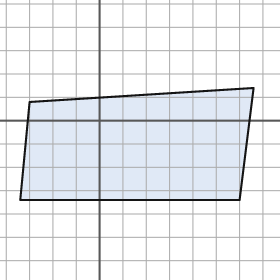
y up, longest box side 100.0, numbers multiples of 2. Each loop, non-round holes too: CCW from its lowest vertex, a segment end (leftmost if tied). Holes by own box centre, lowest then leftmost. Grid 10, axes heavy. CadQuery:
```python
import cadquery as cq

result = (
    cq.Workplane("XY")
    .moveTo(-34.0, -34.0)
    .lineTo(60.0, -34.0)
    .lineTo(66.0, 14.0)
    .lineTo(-30.0, 8.0)
    .close()
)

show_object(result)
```